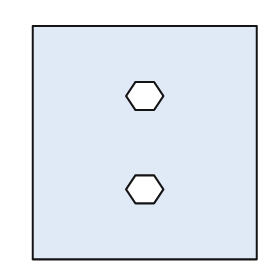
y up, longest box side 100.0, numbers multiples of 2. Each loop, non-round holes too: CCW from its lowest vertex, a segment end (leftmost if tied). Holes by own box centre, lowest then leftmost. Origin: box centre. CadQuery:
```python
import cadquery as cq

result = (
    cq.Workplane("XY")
    .moveTo(-48.0, -50.0)
    .lineTo(48.0, -50.0)
    .lineTo(48.0, 50.0)
    .lineTo(-48.0, 50.0)
    .close()
    .moveTo(-4.0, -26.0)
    .lineTo(4.0, -26.0)
    .lineTo(8.0, -20.0)
    .lineTo(4.0, -14.0)
    .lineTo(-4.0, -14.0)
    .lineTo(-8.0, -20.0)
    .close()
    .moveTo(-4.0, 14.0)
    .lineTo(4.0, 14.0)
    .lineTo(8.0, 20.0)
    .lineTo(4.0, 26.0)
    .lineTo(-4.0, 26.0)
    .lineTo(-8.0, 20.0)
    .close()
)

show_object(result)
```